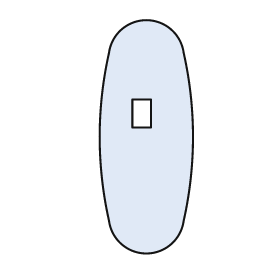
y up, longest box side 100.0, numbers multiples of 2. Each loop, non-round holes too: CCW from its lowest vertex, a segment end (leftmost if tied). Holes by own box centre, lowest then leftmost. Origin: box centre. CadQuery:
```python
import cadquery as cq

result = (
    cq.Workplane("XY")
    .moveTo(-16.0, -36.0)
    .threePointArc((0.0, -50.0), (16.0, -36.0))
    .threePointArc((20.0, 0.0), (16.0, 36.0))
    .threePointArc((0.0, 50.0), (-16.0, 36.0))
    .threePointArc((-20.0, 0.0), (-16.0, -36.0))
    .close()
    .moveTo(-6.0, 4.0)
    .lineTo(2.0, 4.0)
    .lineTo(2.0, 16.0)
    .lineTo(-6.0, 16.0)
    .close()
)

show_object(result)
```